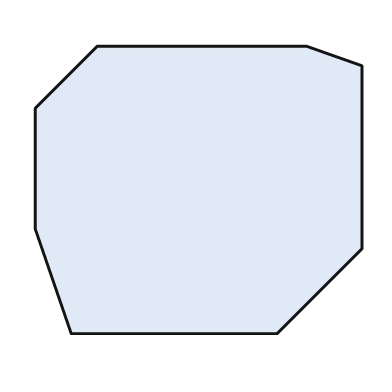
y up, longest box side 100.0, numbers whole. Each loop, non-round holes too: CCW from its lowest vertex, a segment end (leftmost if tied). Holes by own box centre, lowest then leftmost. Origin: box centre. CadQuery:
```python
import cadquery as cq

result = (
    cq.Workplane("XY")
    .moveTo(-39.0, -44.0)
    .lineTo(24.0, -44.0)
    .lineTo(50.0, -18.0)
    .lineTo(50.0, 38.0)
    .lineTo(33.0, 44.0)
    .lineTo(-31.0, 44.0)
    .lineTo(-50.0, 25.0)
    .lineTo(-50.0, -12.0)
    .close()
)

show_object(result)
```